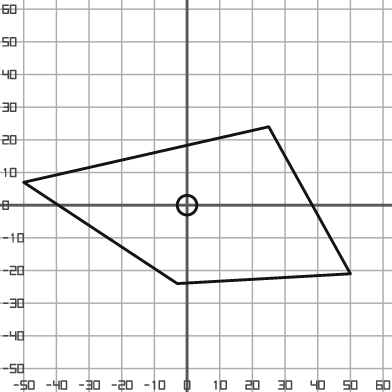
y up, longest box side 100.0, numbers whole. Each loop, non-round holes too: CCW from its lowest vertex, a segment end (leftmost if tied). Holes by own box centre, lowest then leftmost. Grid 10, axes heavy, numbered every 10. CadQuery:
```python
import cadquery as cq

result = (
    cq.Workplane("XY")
    .moveTo(-3.0, -24.0)
    .lineTo(50.0, -21.0)
    .lineTo(25.0, 24.0)
    .lineTo(-50.0, 7.0)
    .close()
    .moveTo(0.0, 0.0)
    .circle(3.0)
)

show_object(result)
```